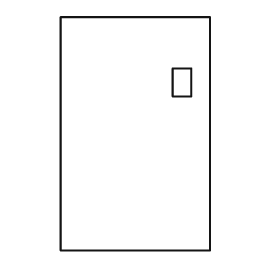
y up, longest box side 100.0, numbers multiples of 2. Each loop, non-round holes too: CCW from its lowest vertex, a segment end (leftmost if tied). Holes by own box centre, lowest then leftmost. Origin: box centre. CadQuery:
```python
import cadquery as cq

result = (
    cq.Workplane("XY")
    .moveTo(-32.0, -50.0)
    .lineTo(32.0, -50.0)
    .lineTo(32.0, 50.0)
    .lineTo(-32.0, 50.0)
    .close()
    .moveTo(16.0, 16.0)
    .lineTo(24.0, 16.0)
    .lineTo(24.0, 28.0)
    .lineTo(16.0, 28.0)
    .close()
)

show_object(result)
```